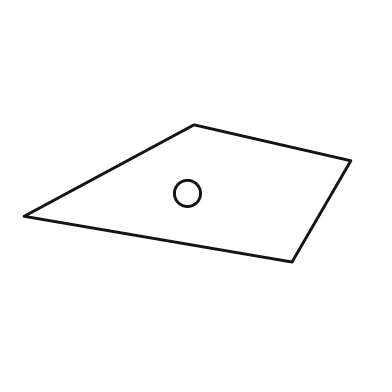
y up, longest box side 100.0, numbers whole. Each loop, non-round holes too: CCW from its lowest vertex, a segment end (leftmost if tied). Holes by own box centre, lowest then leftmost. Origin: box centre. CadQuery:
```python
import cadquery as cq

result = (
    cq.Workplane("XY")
    .moveTo(32.0, -21.0)
    .lineTo(50.0, 10.0)
    .lineTo(2.0, 21.0)
    .lineTo(-50.0, -7.0)
    .close()
    .moveTo(0.0, 0.0)
    .circle(4.0)
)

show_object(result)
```